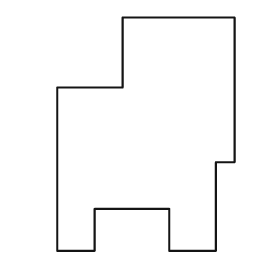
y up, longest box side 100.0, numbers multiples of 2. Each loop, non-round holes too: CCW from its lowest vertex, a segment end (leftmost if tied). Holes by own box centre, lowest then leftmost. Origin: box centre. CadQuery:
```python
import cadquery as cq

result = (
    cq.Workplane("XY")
    .moveTo(-38.0, -50.0)
    .lineTo(-22.0, -50.0)
    .lineTo(-22.0, -32.0)
    .lineTo(10.0, -32.0)
    .lineTo(10.0, -50.0)
    .lineTo(30.0, -50.0)
    .lineTo(30.0, -12.0)
    .lineTo(38.0, -12.0)
    .lineTo(38.0, 50.0)
    .lineTo(-10.0, 50.0)
    .lineTo(-10.0, 20.0)
    .lineTo(-38.0, 20.0)
    .close()
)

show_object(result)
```